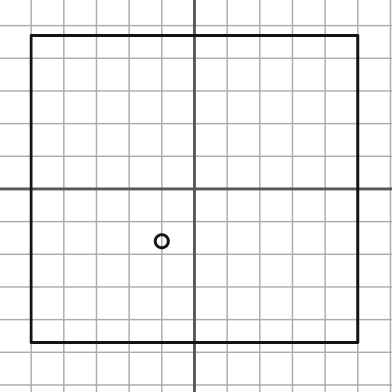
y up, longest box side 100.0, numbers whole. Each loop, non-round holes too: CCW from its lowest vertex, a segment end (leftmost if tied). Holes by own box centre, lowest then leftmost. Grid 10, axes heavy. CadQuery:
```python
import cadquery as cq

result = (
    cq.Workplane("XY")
    .moveTo(-50.0, -47.0)
    .lineTo(50.0, -47.0)
    .lineTo(50.0, 47.0)
    .lineTo(-50.0, 47.0)
    .close()
    .moveTo(-10.0, -16.0)
    .circle(2.0)
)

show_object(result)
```